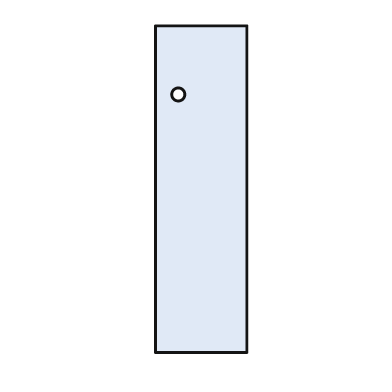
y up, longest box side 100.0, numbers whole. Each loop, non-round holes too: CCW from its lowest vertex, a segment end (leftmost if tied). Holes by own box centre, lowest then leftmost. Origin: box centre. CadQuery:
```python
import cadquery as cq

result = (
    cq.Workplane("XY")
    .moveTo(-14.0, -50.0)
    .lineTo(14.0, -50.0)
    .lineTo(14.0, 50.0)
    .lineTo(-14.0, 50.0)
    .close()
    .moveTo(-7.0, 29.0)
    .circle(2.0)
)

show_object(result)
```